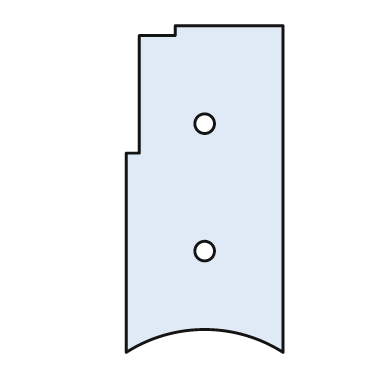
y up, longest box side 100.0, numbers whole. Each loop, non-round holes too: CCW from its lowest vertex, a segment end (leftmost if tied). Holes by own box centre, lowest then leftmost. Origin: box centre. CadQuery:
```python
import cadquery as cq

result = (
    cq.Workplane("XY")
    .moveTo(-24.0, -50.0)
    .threePointArc((0.0, -43.0), (24.0, -50.0))
    .lineTo(24.0, 50.0)
    .lineTo(-9.0, 50.0)
    .lineTo(-9.0, 47.0)
    .lineTo(-20.0, 47.0)
    .lineTo(-20.0, 11.0)
    .lineTo(-24.0, 11.0)
    .close()
    .moveTo(0.0, -19.0)
    .circle(3.0)
    .moveTo(0.0, 20.0)
    .circle(3.0)
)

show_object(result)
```